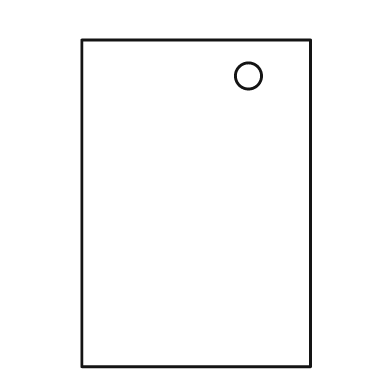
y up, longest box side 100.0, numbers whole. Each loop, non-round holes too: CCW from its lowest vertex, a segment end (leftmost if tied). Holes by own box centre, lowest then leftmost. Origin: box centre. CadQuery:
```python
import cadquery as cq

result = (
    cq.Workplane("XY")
    .moveTo(-35.0, -50.0)
    .lineTo(35.0, -50.0)
    .lineTo(35.0, 50.0)
    .lineTo(-35.0, 50.0)
    .close()
    .moveTo(16.0, 39.0)
    .circle(4.0)
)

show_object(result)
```